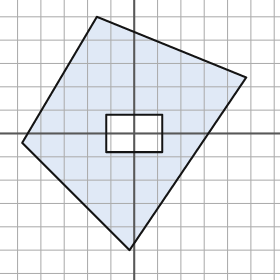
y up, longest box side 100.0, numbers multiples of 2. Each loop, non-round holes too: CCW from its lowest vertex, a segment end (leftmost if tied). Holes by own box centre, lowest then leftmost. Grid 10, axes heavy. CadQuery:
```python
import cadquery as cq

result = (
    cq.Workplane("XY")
    .moveTo(-2.0, -50.0)
    .lineTo(48.0, 24.0)
    .lineTo(-16.0, 50.0)
    .lineTo(-48.0, -4.0)
    .close()
    .moveTo(-12.0, -8.0)
    .lineTo(12.0, -8.0)
    .lineTo(12.0, 8.0)
    .lineTo(-12.0, 8.0)
    .close()
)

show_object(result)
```